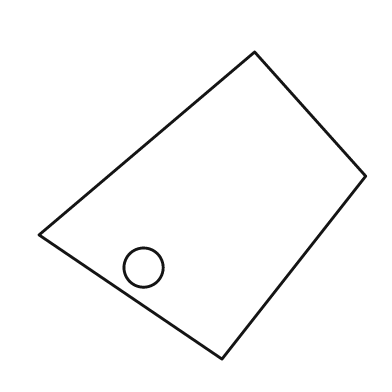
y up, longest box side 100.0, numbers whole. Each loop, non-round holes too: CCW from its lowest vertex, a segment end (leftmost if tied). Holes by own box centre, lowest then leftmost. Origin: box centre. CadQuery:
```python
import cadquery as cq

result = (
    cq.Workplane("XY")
    .moveTo(6.0, -47.0)
    .lineTo(50.0, 9.0)
    .lineTo(16.0, 47.0)
    .lineTo(-50.0, -9.0)
    .close()
    .moveTo(-18.0, -19.0)
    .circle(6.0)
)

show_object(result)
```